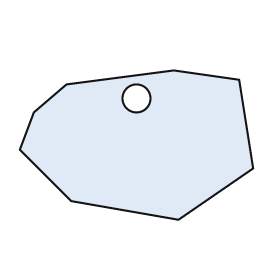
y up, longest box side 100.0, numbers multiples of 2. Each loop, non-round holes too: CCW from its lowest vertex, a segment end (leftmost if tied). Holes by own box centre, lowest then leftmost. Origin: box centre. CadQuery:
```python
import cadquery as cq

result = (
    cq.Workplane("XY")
    .moveTo(18.0, -32.0)
    .lineTo(50.0, -10.0)
    .lineTo(44.0, 28.0)
    .lineTo(16.0, 32.0)
    .lineTo(-30.0, 26.0)
    .lineTo(-44.0, 14.0)
    .lineTo(-50.0, -2.0)
    .lineTo(-28.0, -24.0)
    .close()
    .moveTo(0.0, 20.0)
    .circle(6.0)
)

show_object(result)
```